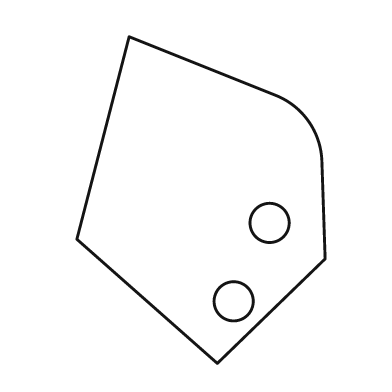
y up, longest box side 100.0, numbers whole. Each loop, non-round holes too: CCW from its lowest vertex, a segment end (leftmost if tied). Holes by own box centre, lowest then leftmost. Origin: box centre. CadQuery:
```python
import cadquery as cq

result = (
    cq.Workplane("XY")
    .moveTo(5.0, -50.0)
    .lineTo(38.0, -18.0)
    .lineTo(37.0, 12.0)
    .threePointArc((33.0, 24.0), (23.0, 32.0))
    .lineTo(-22.0, 50.0)
    .lineTo(-38.0, -12.0)
    .close()
    .moveTo(10.0, -31.0)
    .circle(6.0)
    .moveTo(21.0, -7.0)
    .circle(6.0)
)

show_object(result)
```